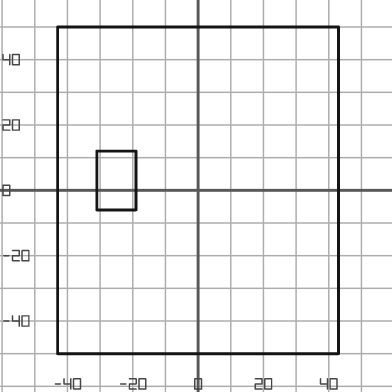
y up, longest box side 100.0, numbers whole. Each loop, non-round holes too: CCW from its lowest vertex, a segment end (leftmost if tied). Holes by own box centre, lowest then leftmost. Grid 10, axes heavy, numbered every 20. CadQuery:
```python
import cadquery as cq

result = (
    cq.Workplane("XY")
    .moveTo(-43.0, -50.0)
    .lineTo(43.0, -50.0)
    .lineTo(43.0, 50.0)
    .lineTo(-43.0, 50.0)
    .close()
    .moveTo(-31.0, -6.0)
    .lineTo(-19.0, -6.0)
    .lineTo(-19.0, 12.0)
    .lineTo(-31.0, 12.0)
    .close()
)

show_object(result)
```